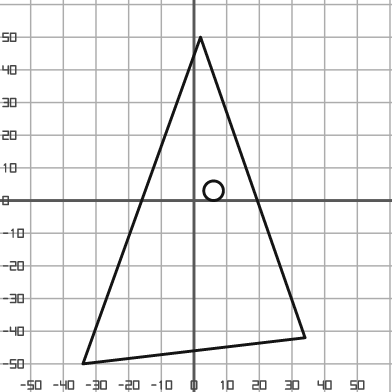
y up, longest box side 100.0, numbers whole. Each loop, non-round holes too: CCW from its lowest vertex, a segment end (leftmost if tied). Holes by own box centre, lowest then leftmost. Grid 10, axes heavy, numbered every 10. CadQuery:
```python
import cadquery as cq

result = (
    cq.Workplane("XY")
    .moveTo(-34.0, -50.0)
    .lineTo(34.0, -42.0)
    .lineTo(2.0, 50.0)
    .close()
    .moveTo(6.0, 3.0)
    .circle(3.0)
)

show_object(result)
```